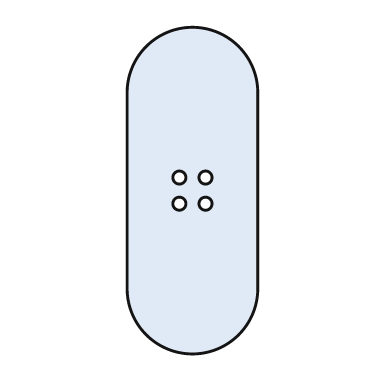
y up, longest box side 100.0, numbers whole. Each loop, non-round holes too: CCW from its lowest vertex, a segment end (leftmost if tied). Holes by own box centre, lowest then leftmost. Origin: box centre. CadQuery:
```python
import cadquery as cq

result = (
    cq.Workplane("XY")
    .moveTo(-20.0, -30.0)
    .threePointArc((0.0, -50.0), (20.0, -30.0))
    .lineTo(20.0, 30.0)
    .threePointArc((0.0, 50.0), (-20.0, 30.0))
    .close()
    .moveTo(-4.0, -4.0)
    .circle(2.0)
    .moveTo(4.0, -4.0)
    .circle(2.0)
    .moveTo(-4.0, 4.0)
    .circle(2.0)
    .moveTo(4.0, 4.0)
    .circle(2.0)
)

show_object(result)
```